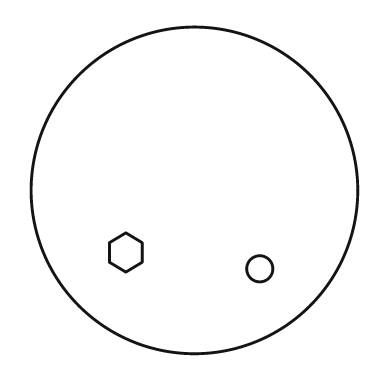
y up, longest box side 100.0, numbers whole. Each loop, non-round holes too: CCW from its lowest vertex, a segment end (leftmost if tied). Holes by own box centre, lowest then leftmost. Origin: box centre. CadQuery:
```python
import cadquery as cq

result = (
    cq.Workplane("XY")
    .moveTo(0.0, 0.0)
    .circle(50.0)
    .moveTo(20.0, -24.0)
    .circle(4.0)
    .moveTo(-21.0, -25.0)
    .lineTo(-16.0, -22.0)
    .lineTo(-16.0, -16.0)
    .lineTo(-21.0, -13.0)
    .lineTo(-26.0, -16.0)
    .lineTo(-26.0, -22.0)
    .close()
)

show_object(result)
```